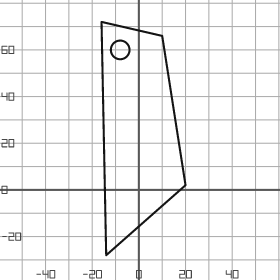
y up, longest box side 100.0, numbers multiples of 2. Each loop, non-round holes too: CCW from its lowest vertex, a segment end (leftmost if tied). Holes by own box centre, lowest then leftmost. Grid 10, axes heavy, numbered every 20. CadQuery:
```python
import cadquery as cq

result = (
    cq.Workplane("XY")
    .moveTo(-14.0, -28.0)
    .lineTo(20.0, 2.0)
    .lineTo(10.0, 66.0)
    .lineTo(-16.0, 72.0)
    .close()
    .moveTo(-8.0, 60.0)
    .circle(4.0)
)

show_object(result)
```